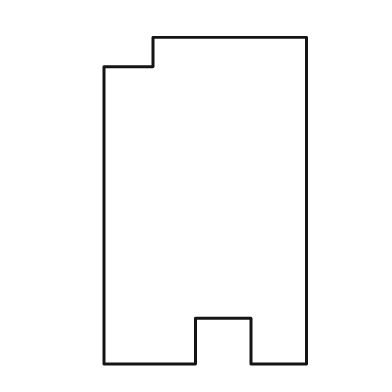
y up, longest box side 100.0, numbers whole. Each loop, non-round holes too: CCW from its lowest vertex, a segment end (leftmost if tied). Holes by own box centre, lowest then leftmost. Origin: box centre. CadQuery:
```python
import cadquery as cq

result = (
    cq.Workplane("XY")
    .moveTo(-31.0, -50.0)
    .lineTo(-3.0, -50.0)
    .lineTo(-3.0, -36.0)
    .lineTo(14.0, -36.0)
    .lineTo(14.0, -50.0)
    .lineTo(31.0, -50.0)
    .lineTo(31.0, 50.0)
    .lineTo(-16.0, 50.0)
    .lineTo(-16.0, 41.0)
    .lineTo(-31.0, 41.0)
    .close()
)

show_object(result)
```